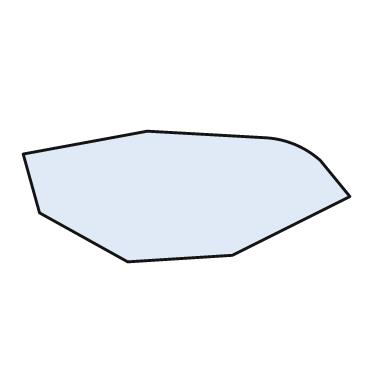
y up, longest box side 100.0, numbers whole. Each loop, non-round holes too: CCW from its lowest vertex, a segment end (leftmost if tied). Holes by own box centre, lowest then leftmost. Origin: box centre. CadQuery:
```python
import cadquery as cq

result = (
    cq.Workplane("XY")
    .moveTo(-18.0, -20.0)
    .lineTo(14.0, -18.0)
    .lineTo(50.0, 0.0)
    .lineTo(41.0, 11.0)
    .threePointArc((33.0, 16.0), (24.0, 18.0))
    .lineTo(-12.0, 20.0)
    .lineTo(-50.0, 13.0)
    .lineTo(-45.0, -5.0)
    .close()
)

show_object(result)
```